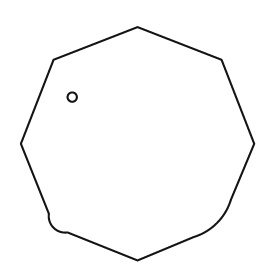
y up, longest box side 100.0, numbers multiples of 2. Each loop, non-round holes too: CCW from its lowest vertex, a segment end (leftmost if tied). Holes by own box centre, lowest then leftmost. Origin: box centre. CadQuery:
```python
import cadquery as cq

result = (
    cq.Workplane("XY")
    .moveTo(0.0, -50.0)
    .lineTo(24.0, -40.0)
    .threePointArc((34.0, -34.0), (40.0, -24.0))
    .lineTo(50.0, 0.0)
    .lineTo(36.0, 36.0)
    .lineTo(0.0, 50.0)
    .lineTo(-36.0, 36.0)
    .lineTo(-50.0, 0.0)
    .lineTo(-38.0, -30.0)
    .threePointArc((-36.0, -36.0), (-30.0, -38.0))
    .close()
    .moveTo(-28.0, 20.0)
    .circle(2.0)
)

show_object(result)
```